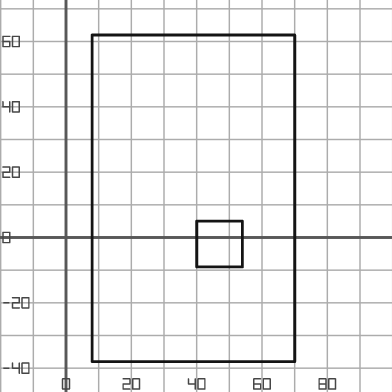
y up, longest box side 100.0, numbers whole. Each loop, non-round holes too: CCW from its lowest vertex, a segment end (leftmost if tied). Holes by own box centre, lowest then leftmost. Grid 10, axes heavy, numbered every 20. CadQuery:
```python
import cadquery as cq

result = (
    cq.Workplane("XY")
    .moveTo(8.0, -38.0)
    .lineTo(70.0, -38.0)
    .lineTo(70.0, 62.0)
    .lineTo(8.0, 62.0)
    .close()
    .moveTo(40.0, -9.0)
    .lineTo(54.0, -9.0)
    .lineTo(54.0, 5.0)
    .lineTo(40.0, 5.0)
    .close()
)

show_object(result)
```